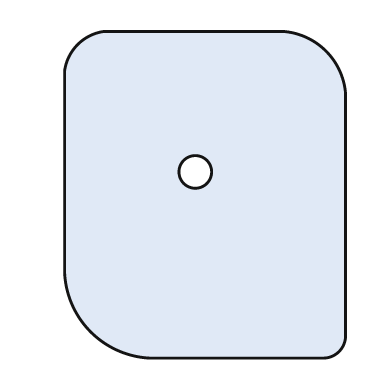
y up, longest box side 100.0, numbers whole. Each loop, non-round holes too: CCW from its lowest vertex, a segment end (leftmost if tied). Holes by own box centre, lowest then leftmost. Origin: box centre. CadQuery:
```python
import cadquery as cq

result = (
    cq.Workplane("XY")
    .moveTo(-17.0, -50.0)
    .lineTo(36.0, -50.0)
    .threePointArc((41.0, -48.0), (43.0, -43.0))
    .lineTo(43.0, 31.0)
    .threePointArc((37.0, 44.0), (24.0, 50.0))
    .lineTo(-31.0, 50.0)
    .threePointArc((-39.0, 46.0), (-43.0, 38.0))
    .lineTo(-43.0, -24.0)
    .threePointArc((-35.0, -42.0), (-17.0, -50.0))
    .close()
    .moveTo(-3.0, 7.0)
    .circle(5.0)
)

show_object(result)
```